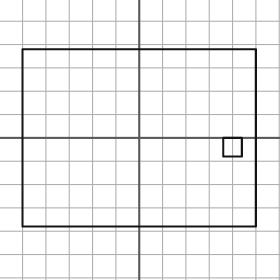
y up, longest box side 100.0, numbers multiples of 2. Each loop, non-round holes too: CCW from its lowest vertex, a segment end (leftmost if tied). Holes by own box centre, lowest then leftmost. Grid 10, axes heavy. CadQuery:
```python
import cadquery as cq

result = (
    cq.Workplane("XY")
    .moveTo(-50.0, -38.0)
    .lineTo(50.0, -38.0)
    .lineTo(50.0, 38.0)
    .lineTo(-50.0, 38.0)
    .close()
    .moveTo(36.0, -8.0)
    .lineTo(44.0, -8.0)
    .lineTo(44.0, 0.0)
    .lineTo(36.0, 0.0)
    .close()
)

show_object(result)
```